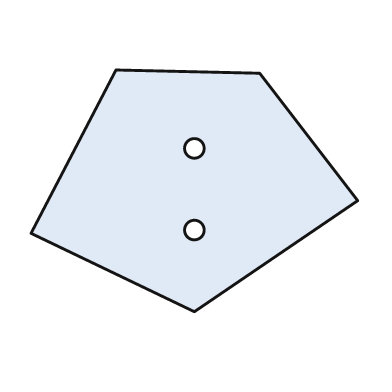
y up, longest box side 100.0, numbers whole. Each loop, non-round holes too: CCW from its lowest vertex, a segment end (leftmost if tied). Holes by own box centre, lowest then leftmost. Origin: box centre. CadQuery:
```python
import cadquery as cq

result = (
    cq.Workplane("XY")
    .moveTo(0.0, -37.0)
    .lineTo(50.0, -3.0)
    .lineTo(20.0, 36.0)
    .lineTo(-24.0, 37.0)
    .lineTo(-50.0, -13.0)
    .close()
    .moveTo(0.0, -12.0)
    .circle(3.0)
    .moveTo(0.0, 13.0)
    .circle(3.0)
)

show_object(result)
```